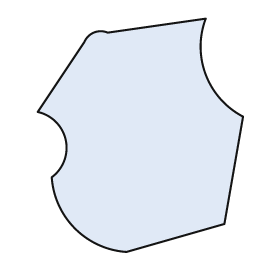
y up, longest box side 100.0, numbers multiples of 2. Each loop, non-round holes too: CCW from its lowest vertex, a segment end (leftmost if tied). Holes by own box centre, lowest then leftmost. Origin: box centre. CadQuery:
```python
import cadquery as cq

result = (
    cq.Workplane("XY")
    .moveTo(-6.0, -50.0)
    .lineTo(36.0, -38.0)
    .lineTo(44.0, 8.0)
    .threePointArc((28.0, 26.0), (28.0, 50.0))
    .lineTo(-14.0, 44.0)
    .threePointArc((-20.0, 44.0), (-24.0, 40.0))
    .lineTo(-44.0, 10.0)
    .threePointArc((-32.0, -2.0), (-38.0, -18.0))
    .threePointArc((-28.0, -40.0), (-6.0, -50.0))
    .close()
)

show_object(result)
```